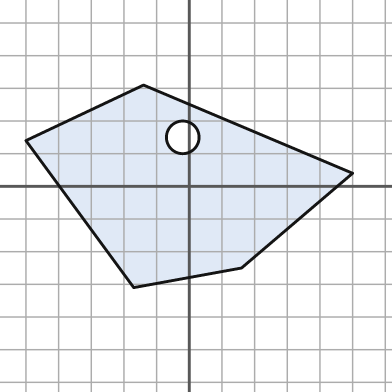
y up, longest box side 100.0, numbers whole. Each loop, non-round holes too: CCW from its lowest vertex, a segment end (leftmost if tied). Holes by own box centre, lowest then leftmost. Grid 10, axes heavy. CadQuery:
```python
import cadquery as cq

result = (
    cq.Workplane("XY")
    .moveTo(-17.0, -31.0)
    .lineTo(16.0, -25.0)
    .lineTo(50.0, 4.0)
    .lineTo(-14.0, 31.0)
    .lineTo(-50.0, 14.0)
    .close()
    .moveTo(-2.0, 15.0)
    .circle(5.0)
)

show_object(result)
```